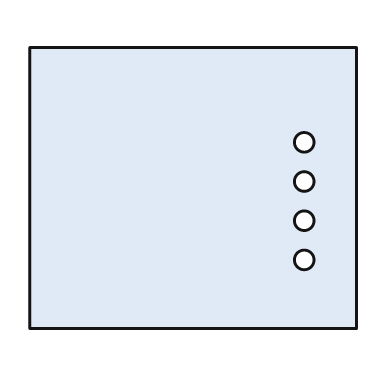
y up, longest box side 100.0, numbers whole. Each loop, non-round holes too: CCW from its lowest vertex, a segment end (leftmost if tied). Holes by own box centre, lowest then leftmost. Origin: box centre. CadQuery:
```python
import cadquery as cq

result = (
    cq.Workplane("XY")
    .moveTo(-50.0, -43.0)
    .lineTo(50.0, -43.0)
    .lineTo(50.0, 43.0)
    .lineTo(-50.0, 43.0)
    .close()
    .moveTo(34.0, -22.0)
    .circle(3.0)
    .moveTo(34.0, -10.0)
    .circle(3.0)
    .moveTo(34.0, 2.0)
    .circle(3.0)
    .moveTo(34.0, 14.0)
    .circle(3.0)
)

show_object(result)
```